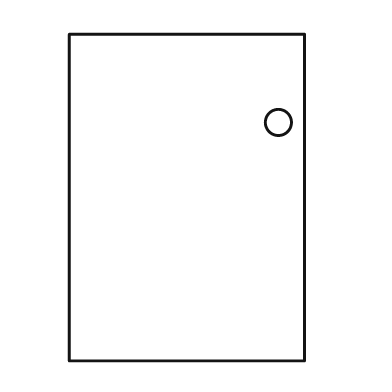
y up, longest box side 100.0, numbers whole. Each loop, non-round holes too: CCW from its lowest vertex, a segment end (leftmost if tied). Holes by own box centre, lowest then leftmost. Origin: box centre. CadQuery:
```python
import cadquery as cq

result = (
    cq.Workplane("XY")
    .moveTo(-36.0, -50.0)
    .lineTo(36.0, -50.0)
    .lineTo(36.0, 50.0)
    .lineTo(-36.0, 50.0)
    .close()
    .moveTo(28.0, 23.0)
    .circle(4.0)
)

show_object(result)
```